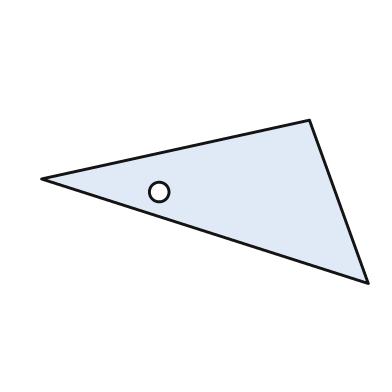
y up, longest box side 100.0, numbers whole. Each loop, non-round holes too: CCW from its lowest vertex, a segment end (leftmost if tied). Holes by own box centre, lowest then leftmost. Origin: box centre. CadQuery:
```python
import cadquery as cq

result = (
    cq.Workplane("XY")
    .moveTo(50.0, -25.0)
    .lineTo(32.0, 25.0)
    .lineTo(-50.0, 7.0)
    .close()
    .moveTo(-14.0, 3.0)
    .circle(3.0)
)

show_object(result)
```